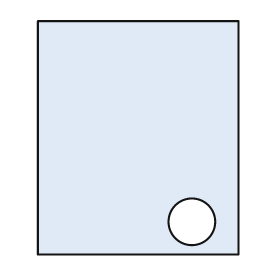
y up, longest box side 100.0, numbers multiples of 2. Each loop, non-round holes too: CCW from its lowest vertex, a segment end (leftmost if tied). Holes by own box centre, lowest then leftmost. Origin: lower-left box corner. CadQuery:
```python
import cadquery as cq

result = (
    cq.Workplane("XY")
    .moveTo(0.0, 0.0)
    .lineTo(86.0, 0.0)
    .lineTo(86.0, 100.0)
    .lineTo(0.0, 100.0)
    .close()
    .moveTo(66.0, 14.0)
    .circle(10.0)
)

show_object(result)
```